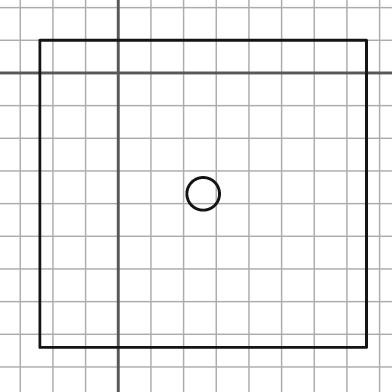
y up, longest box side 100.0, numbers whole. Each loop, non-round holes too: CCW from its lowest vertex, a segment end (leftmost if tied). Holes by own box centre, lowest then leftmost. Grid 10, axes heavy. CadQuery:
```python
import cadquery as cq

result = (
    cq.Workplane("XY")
    .moveTo(-24.0, -84.0)
    .lineTo(76.0, -84.0)
    .lineTo(76.0, 10.0)
    .lineTo(-24.0, 10.0)
    .close()
    .moveTo(26.0, -37.0)
    .circle(5.0)
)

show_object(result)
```